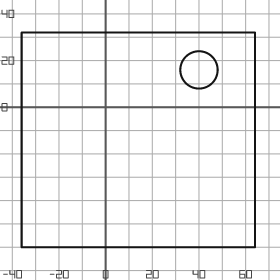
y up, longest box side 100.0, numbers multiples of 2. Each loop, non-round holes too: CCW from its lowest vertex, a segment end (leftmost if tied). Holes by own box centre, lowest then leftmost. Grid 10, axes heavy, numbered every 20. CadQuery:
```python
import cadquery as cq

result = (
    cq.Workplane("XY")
    .moveTo(-36.0, -60.0)
    .lineTo(64.0, -60.0)
    .lineTo(64.0, 32.0)
    .lineTo(-36.0, 32.0)
    .close()
    .moveTo(40.0, 16.0)
    .circle(8.0)
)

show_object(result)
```